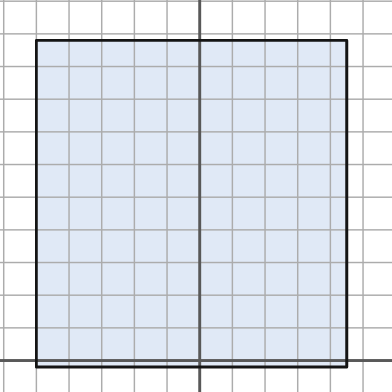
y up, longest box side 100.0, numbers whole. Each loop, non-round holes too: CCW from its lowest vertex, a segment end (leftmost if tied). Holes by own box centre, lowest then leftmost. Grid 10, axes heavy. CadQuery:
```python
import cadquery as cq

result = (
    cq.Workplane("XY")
    .moveTo(-50.0, -2.0)
    .lineTo(45.0, -2.0)
    .lineTo(45.0, 98.0)
    .lineTo(-50.0, 98.0)
    .close()
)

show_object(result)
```